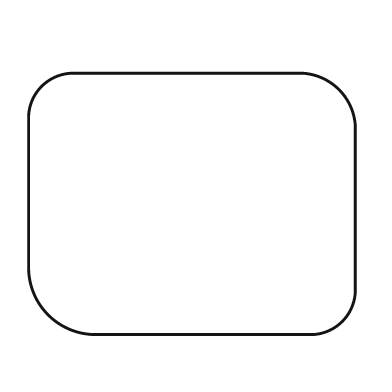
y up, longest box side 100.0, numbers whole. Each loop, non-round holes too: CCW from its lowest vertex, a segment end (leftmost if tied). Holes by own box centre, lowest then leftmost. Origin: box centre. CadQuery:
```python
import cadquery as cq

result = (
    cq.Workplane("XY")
    .moveTo(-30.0, -40.0)
    .lineTo(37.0, -40.0)
    .threePointArc((46.0, -36.0), (50.0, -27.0))
    .lineTo(50.0, 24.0)
    .threePointArc((45.0, 35.0), (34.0, 40.0))
    .lineTo(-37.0, 40.0)
    .threePointArc((-46.0, 36.0), (-50.0, 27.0))
    .lineTo(-50.0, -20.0)
    .threePointArc((-44.0, -34.0), (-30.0, -40.0))
    .close()
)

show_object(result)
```